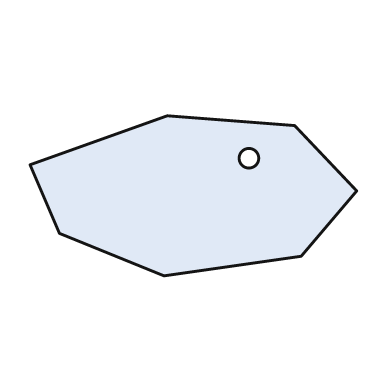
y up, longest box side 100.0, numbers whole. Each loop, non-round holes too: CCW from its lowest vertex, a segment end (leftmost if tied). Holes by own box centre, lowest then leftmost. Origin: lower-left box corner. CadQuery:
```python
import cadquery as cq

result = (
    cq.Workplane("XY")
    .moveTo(41.0, 0.0)
    .lineTo(83.0, 6.0)
    .lineTo(100.0, 26.0)
    .lineTo(81.0, 46.0)
    .lineTo(42.0, 49.0)
    .lineTo(0.0, 34.0)
    .lineTo(9.0, 13.0)
    .close()
    .moveTo(67.0, 36.0)
    .circle(3.0)
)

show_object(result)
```